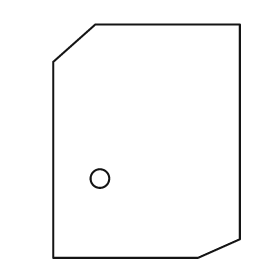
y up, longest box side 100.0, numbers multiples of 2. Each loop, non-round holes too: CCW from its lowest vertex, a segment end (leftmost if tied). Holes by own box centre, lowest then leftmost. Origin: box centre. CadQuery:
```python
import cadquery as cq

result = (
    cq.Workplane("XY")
    .moveTo(-40.0, -50.0)
    .lineTo(22.0, -50.0)
    .lineTo(40.0, -42.0)
    .lineTo(40.0, 50.0)
    .lineTo(-22.0, 50.0)
    .lineTo(-40.0, 34.0)
    .close()
    .moveTo(-20.0, -16.0)
    .circle(4.0)
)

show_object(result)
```